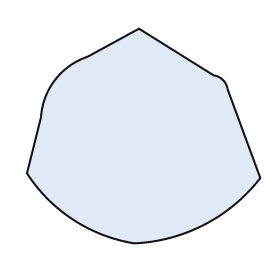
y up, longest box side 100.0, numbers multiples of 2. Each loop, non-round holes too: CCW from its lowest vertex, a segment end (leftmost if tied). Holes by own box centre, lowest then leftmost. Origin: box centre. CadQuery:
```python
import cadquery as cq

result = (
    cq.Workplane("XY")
    .moveTo(-4.0, -46.0)
    .threePointArc((26.0, -38.0), (50.0, -18.0))
    .lineTo(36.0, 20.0)
    .threePointArc((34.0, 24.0), (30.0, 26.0))
    .lineTo(-2.0, 46.0)
    .lineTo(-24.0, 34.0)
    .threePointArc((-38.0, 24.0), (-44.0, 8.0))
    .lineTo(-50.0, -16.0)
    .threePointArc((-30.0, -36.0), (-4.0, -46.0))
    .close()
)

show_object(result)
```